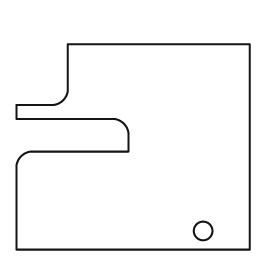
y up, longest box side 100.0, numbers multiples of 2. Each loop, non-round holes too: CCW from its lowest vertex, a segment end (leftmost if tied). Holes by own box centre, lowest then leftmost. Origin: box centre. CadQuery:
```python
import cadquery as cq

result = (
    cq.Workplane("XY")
    .moveTo(-50.0, -44.0)
    .lineTo(50.0, -44.0)
    .lineTo(50.0, 44.0)
    .lineTo(-28.0, 44.0)
    .lineTo(-28.0, 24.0)
    .threePointArc((-30.0, 20.0), (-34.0, 18.0))
    .lineTo(-50.0, 18.0)
    .lineTo(-50.0, 12.0)
    .lineTo(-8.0, 12.0)
    .threePointArc((-4.0, 10.0), (-2.0, 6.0))
    .lineTo(-2.0, -2.0)
    .lineTo(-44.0, -2.0)
    .threePointArc((-48.0, -4.0), (-50.0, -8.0))
    .close()
    .moveTo(30.0, -36.0)
    .circle(4.0)
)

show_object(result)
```